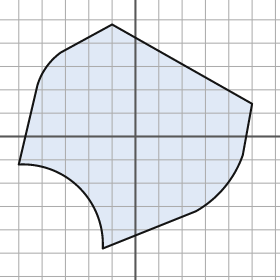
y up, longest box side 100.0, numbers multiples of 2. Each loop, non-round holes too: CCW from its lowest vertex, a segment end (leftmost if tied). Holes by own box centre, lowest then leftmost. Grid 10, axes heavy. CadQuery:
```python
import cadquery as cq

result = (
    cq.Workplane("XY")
    .moveTo(-14.0, -48.0)
    .lineTo(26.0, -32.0)
    .threePointArc((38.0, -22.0), (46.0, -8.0))
    .lineTo(50.0, 14.0)
    .lineTo(-10.0, 48.0)
    .lineTo(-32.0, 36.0)
    .threePointArc((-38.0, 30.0), (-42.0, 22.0))
    .lineTo(-50.0, -12.0)
    .threePointArc((-24.0, -22.0), (-14.0, -48.0))
    .close()
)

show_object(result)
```